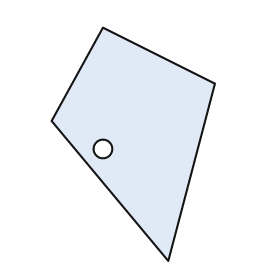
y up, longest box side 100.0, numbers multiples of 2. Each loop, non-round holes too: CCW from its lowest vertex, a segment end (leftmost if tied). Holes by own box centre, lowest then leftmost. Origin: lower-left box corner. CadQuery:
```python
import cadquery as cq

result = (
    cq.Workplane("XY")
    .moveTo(50.0, 0.0)
    .lineTo(70.0, 76.0)
    .lineTo(22.0, 100.0)
    .lineTo(0.0, 60.0)
    .close()
    .moveTo(22.0, 48.0)
    .circle(4.0)
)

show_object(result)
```